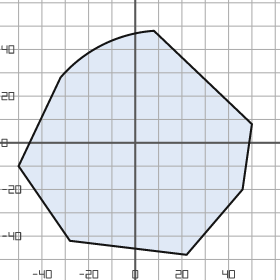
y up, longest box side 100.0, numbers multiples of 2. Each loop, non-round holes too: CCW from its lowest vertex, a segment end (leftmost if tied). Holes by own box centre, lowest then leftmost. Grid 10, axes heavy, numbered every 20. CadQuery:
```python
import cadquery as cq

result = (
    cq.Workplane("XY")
    .moveTo(22.0, -48.0)
    .lineTo(46.0, -20.0)
    .lineTo(50.0, 8.0)
    .lineTo(8.0, 48.0)
    .threePointArc((-14.0, 42.0), (-32.0, 28.0))
    .lineTo(-50.0, -10.0)
    .lineTo(-28.0, -42.0)
    .close()
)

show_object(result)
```